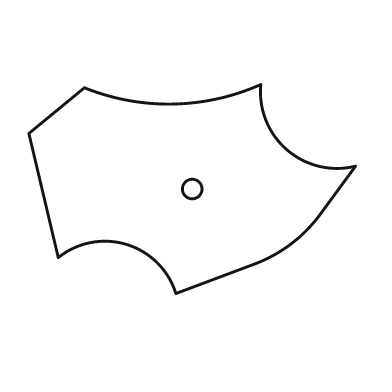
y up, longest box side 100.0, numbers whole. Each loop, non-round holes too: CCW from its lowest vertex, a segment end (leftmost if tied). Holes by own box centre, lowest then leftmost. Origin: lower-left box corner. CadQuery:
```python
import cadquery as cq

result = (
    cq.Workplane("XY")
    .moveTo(45.0, 0.0)
    .lineTo(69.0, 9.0)
    .threePointArc((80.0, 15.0), (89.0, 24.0))
    .lineTo(100.0, 39.0)
    .threePointArc((79.0, 44.0), (71.0, 64.0))
    .threePointArc((44.0, 58.0), (17.0, 63.0))
    .lineTo(0.0, 49.0)
    .lineTo(9.0, 11.0)
    .threePointArc((30.0, 15.0), (45.0, 0.0))
    .close()
    .moveTo(50.0, 32.0)
    .circle(3.0)
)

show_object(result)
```